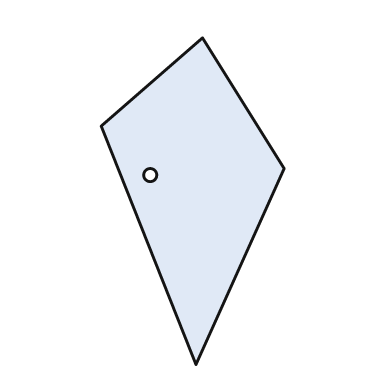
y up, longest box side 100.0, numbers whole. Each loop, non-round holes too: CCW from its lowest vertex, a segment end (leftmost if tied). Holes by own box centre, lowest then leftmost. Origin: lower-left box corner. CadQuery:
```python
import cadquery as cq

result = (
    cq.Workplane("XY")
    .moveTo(29.0, 0.0)
    .lineTo(56.0, 60.0)
    .lineTo(31.0, 100.0)
    .lineTo(0.0, 73.0)
    .close()
    .moveTo(15.0, 58.0)
    .circle(2.0)
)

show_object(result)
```